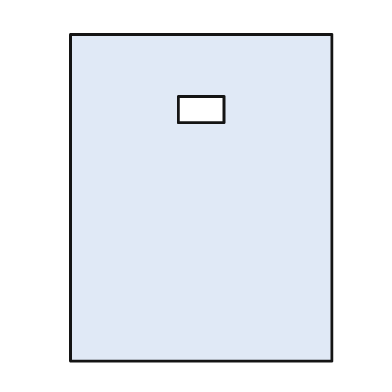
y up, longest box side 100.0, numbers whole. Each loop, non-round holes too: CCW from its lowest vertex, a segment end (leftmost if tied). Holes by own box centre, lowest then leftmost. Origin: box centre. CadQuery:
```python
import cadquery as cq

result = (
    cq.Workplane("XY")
    .moveTo(-40.0, -50.0)
    .lineTo(40.0, -50.0)
    .lineTo(40.0, 50.0)
    .lineTo(-40.0, 50.0)
    .close()
    .moveTo(-7.0, 23.0)
    .lineTo(7.0, 23.0)
    .lineTo(7.0, 31.0)
    .lineTo(-7.0, 31.0)
    .close()
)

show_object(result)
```